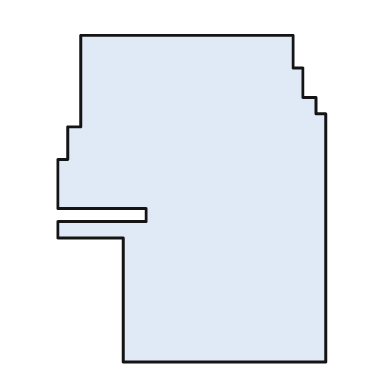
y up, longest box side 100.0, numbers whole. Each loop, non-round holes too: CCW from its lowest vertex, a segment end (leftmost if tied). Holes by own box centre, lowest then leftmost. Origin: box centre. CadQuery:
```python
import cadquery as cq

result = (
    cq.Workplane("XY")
    .moveTo(-21.0, -50.0)
    .lineTo(41.0, -50.0)
    .lineTo(41.0, 26.0)
    .lineTo(38.0, 26.0)
    .lineTo(38.0, 31.0)
    .lineTo(34.0, 31.0)
    .lineTo(34.0, 40.0)
    .lineTo(31.0, 40.0)
    .lineTo(31.0, 50.0)
    .lineTo(-34.0, 50.0)
    .lineTo(-34.0, 22.0)
    .lineTo(-38.0, 22.0)
    .lineTo(-38.0, 12.0)
    .lineTo(-41.0, 12.0)
    .lineTo(-41.0, -3.0)
    .lineTo(-14.0, -3.0)
    .lineTo(-14.0, -7.0)
    .lineTo(-41.0, -7.0)
    .lineTo(-41.0, -12.0)
    .lineTo(-21.0, -12.0)
    .close()
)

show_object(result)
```